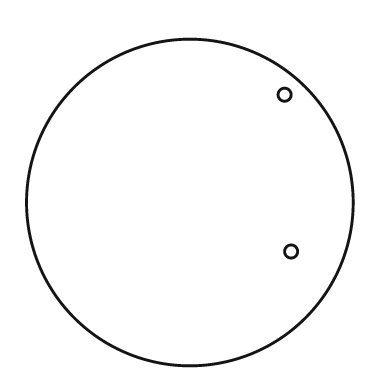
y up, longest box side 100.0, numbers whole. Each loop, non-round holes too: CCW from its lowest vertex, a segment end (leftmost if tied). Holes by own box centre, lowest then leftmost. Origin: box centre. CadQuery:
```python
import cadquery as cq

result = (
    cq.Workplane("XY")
    .moveTo(0.0, 0.0)
    .circle(50.0)
    .moveTo(31.0, -15.0)
    .circle(2.0)
    .moveTo(29.0, 33.0)
    .circle(2.0)
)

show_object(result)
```